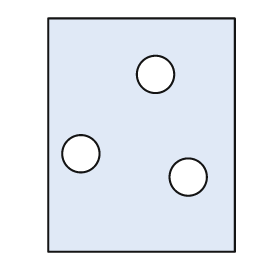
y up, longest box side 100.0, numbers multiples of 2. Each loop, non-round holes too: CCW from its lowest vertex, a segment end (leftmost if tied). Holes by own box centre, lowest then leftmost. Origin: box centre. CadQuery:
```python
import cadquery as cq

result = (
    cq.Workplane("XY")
    .moveTo(-40.0, -50.0)
    .lineTo(40.0, -50.0)
    .lineTo(40.0, 50.0)
    .lineTo(-40.0, 50.0)
    .close()
    .moveTo(20.0, -18.0)
    .circle(8.0)
    .moveTo(-26.0, -8.0)
    .circle(8.0)
    .moveTo(6.0, 26.0)
    .circle(8.0)
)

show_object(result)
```